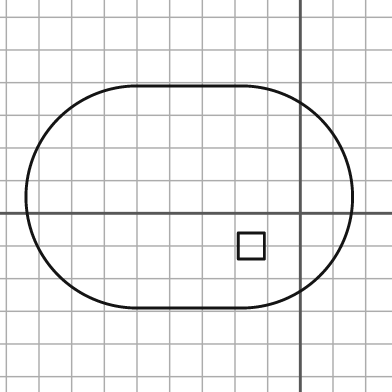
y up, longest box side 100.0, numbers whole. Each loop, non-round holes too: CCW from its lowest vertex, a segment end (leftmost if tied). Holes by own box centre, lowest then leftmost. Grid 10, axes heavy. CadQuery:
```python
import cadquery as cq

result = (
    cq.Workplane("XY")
    .moveTo(-50.0, -29.0)
    .lineTo(-18.0, -29.0)
    .threePointArc((16.0, 5.0), (-18.0, 39.0))
    .lineTo(-50.0, 39.0)
    .threePointArc((-84.0, 5.0), (-50.0, -29.0))
    .close()
    .moveTo(-19.0, -14.0)
    .lineTo(-11.0, -14.0)
    .lineTo(-11.0, -6.0)
    .lineTo(-19.0, -6.0)
    .close()
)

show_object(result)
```